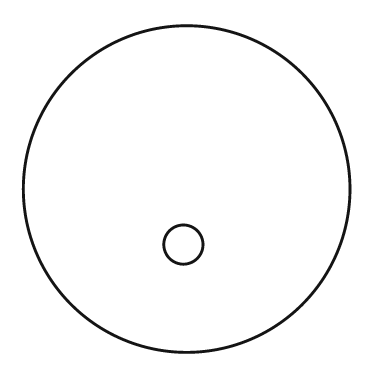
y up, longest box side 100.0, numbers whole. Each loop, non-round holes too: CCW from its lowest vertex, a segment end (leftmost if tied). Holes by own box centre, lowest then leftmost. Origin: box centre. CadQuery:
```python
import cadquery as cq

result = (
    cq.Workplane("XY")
    .moveTo(0.0, 0.0)
    .circle(50.0)
    .moveTo(-1.0, -17.0)
    .circle(6.0)
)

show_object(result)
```